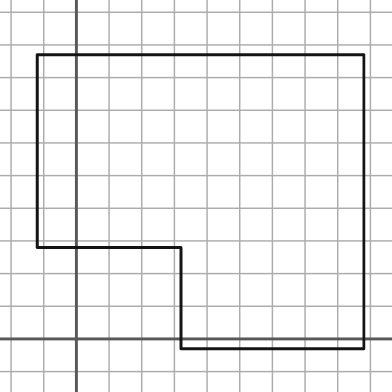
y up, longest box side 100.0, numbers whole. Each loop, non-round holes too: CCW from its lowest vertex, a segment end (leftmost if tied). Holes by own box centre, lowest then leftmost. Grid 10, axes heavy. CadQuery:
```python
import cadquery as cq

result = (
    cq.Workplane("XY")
    .moveTo(32.0, -3.0)
    .lineTo(88.0, -3.0)
    .lineTo(88.0, 87.0)
    .lineTo(-12.0, 87.0)
    .lineTo(-12.0, 28.0)
    .lineTo(32.0, 28.0)
    .close()
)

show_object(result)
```